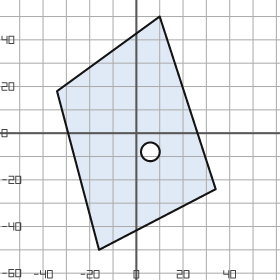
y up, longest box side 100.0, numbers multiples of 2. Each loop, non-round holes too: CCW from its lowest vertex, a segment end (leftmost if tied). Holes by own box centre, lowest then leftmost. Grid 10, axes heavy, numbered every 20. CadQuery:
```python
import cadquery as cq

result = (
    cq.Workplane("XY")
    .moveTo(-16.0, -50.0)
    .lineTo(34.0, -24.0)
    .lineTo(10.0, 50.0)
    .lineTo(-34.0, 18.0)
    .close()
    .moveTo(6.0, -8.0)
    .circle(4.0)
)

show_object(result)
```